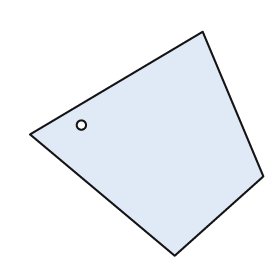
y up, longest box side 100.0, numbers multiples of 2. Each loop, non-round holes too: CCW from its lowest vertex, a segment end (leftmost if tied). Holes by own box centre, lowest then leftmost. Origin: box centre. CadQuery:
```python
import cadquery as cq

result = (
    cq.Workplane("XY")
    .moveTo(12.0, -48.0)
    .lineTo(50.0, -14.0)
    .lineTo(24.0, 48.0)
    .lineTo(-50.0, 4.0)
    .close()
    .moveTo(-28.0, 8.0)
    .circle(2.0)
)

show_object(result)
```